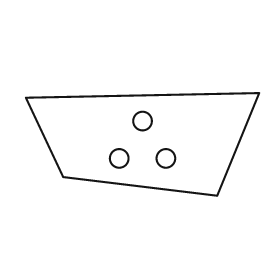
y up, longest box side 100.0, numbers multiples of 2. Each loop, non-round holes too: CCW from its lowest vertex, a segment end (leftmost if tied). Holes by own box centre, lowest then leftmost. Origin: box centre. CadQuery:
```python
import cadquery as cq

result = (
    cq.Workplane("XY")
    .moveTo(32.0, -22.0)
    .lineTo(50.0, 22.0)
    .lineTo(-50.0, 20.0)
    .lineTo(-34.0, -14.0)
    .close()
    .moveTo(-10.0, -6.0)
    .circle(4.0)
    .moveTo(10.0, -6.0)
    .circle(4.0)
    .moveTo(0.0, 10.0)
    .circle(4.0)
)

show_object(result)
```